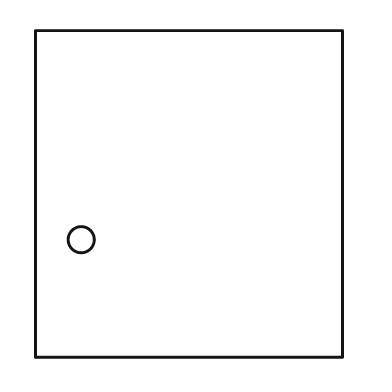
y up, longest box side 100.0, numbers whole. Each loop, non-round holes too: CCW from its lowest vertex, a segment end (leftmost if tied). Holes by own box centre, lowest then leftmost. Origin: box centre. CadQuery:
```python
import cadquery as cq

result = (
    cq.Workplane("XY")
    .moveTo(-47.0, -50.0)
    .lineTo(47.0, -50.0)
    .lineTo(47.0, 50.0)
    .lineTo(-47.0, 50.0)
    .close()
    .moveTo(-33.0, -14.0)
    .circle(4.0)
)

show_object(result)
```